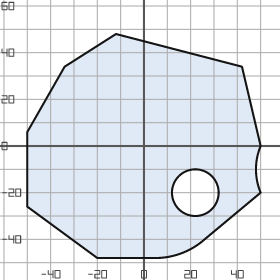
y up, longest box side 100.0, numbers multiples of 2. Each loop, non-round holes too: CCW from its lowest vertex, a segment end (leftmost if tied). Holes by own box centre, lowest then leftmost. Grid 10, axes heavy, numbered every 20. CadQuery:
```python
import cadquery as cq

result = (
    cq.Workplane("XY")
    .moveTo(-20.0, -48.0)
    .lineTo(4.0, -48.0)
    .threePointArc((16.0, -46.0), (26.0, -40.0))
    .lineTo(50.0, -20.0)
    .threePointArc((48.0, -10.0), (50.0, 0.0))
    .lineTo(42.0, 34.0)
    .lineTo(-12.0, 48.0)
    .lineTo(-34.0, 34.0)
    .lineTo(-50.0, 6.0)
    .lineTo(-50.0, -26.0)
    .close()
    .moveTo(22.0, -20.0)
    .circle(10.0)
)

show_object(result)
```